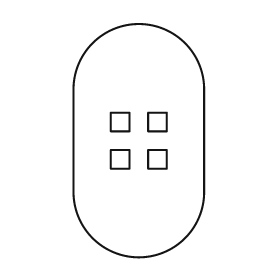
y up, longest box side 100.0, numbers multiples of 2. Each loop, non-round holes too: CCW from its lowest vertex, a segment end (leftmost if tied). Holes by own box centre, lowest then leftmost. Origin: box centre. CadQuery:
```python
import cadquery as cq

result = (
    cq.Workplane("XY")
    .moveTo(-28.0, -22.0)
    .threePointArc((0.0, -50.0), (28.0, -22.0))
    .lineTo(28.0, 22.0)
    .threePointArc((0.0, 50.0), (-28.0, 22.0))
    .close()
    .moveTo(-12.0, -12.0)
    .lineTo(-4.0, -12.0)
    .lineTo(-4.0, -4.0)
    .lineTo(-12.0, -4.0)
    .close()
    .moveTo(4.0, -12.0)
    .lineTo(12.0, -12.0)
    .lineTo(12.0, -4.0)
    .lineTo(4.0, -4.0)
    .close()
    .moveTo(-12.0, 4.0)
    .lineTo(-4.0, 4.0)
    .lineTo(-4.0, 12.0)
    .lineTo(-12.0, 12.0)
    .close()
    .moveTo(4.0, 4.0)
    .lineTo(12.0, 4.0)
    .lineTo(12.0, 12.0)
    .lineTo(4.0, 12.0)
    .close()
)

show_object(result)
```